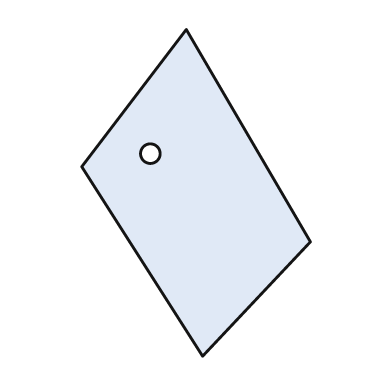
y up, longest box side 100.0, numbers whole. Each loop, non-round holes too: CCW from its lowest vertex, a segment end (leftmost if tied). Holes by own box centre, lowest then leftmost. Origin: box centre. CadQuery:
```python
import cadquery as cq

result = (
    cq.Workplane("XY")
    .moveTo(2.0, -50.0)
    .lineTo(35.0, -15.0)
    .lineTo(-3.0, 50.0)
    .lineTo(-35.0, 8.0)
    .close()
    .moveTo(-14.0, 12.0)
    .circle(3.0)
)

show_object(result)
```